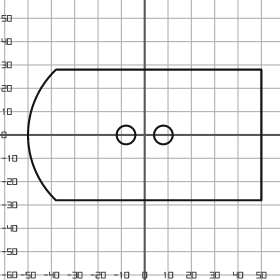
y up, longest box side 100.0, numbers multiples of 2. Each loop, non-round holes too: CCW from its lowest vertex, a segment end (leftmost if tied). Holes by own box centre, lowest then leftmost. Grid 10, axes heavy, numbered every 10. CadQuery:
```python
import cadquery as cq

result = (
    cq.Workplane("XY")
    .moveTo(-38.0, -28.0)
    .lineTo(50.0, -28.0)
    .lineTo(50.0, 28.0)
    .lineTo(-38.0, 28.0)
    .threePointArc((-50.0, 0.0), (-38.0, -28.0))
    .close()
    .moveTo(-8.0, 0.0)
    .circle(4.0)
    .moveTo(8.0, 0.0)
    .circle(4.0)
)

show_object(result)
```